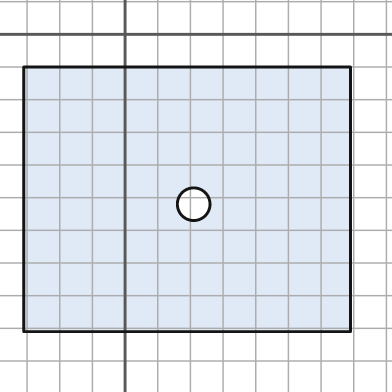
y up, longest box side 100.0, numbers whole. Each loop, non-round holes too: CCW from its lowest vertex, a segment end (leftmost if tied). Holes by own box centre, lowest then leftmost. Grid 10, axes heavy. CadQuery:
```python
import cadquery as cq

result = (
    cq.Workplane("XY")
    .moveTo(-31.0, -91.0)
    .lineTo(69.0, -91.0)
    .lineTo(69.0, -10.0)
    .lineTo(-31.0, -10.0)
    .close()
    .moveTo(21.0, -52.0)
    .circle(5.0)
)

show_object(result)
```